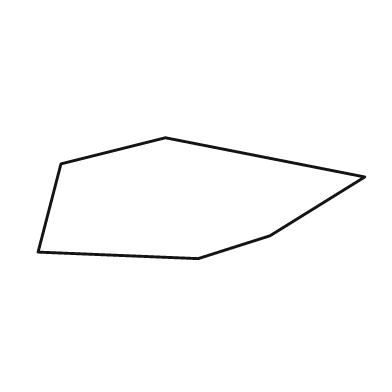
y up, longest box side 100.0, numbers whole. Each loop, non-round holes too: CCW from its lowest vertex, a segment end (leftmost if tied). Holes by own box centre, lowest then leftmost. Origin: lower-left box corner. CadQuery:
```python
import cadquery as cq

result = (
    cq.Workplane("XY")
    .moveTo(49.0, 0.0)
    .lineTo(71.0, 7.0)
    .lineTo(100.0, 25.0)
    .lineTo(39.0, 37.0)
    .lineTo(7.0, 29.0)
    .lineTo(0.0, 2.0)
    .close()
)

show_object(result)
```